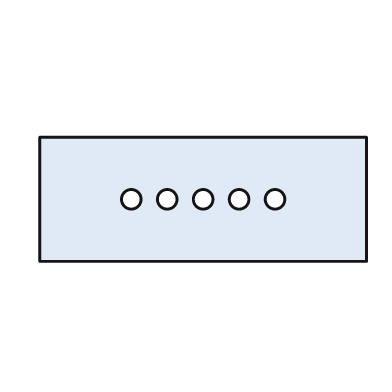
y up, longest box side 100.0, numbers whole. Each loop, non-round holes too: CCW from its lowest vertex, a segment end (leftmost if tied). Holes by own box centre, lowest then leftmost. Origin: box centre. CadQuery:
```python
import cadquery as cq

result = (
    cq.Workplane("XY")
    .moveTo(-50.0, -19.0)
    .lineTo(50.0, -19.0)
    .lineTo(50.0, 19.0)
    .lineTo(-50.0, 19.0)
    .close()
    .moveTo(-22.0, 0.0)
    .circle(3.0)
    .moveTo(-11.0, 0.0)
    .circle(3.0)
    .moveTo(0.0, 0.0)
    .circle(3.0)
    .moveTo(11.0, 0.0)
    .circle(3.0)
    .moveTo(22.0, 0.0)
    .circle(3.0)
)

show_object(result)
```